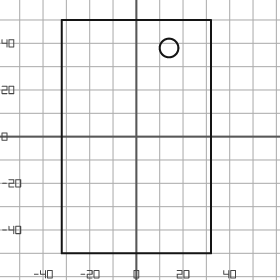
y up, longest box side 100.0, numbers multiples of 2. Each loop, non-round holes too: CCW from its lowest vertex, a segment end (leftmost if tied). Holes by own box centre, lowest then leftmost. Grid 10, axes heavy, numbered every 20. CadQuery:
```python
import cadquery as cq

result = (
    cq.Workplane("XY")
    .moveTo(-32.0, -50.0)
    .lineTo(32.0, -50.0)
    .lineTo(32.0, 50.0)
    .lineTo(-32.0, 50.0)
    .close()
    .moveTo(14.0, 38.0)
    .circle(4.0)
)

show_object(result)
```